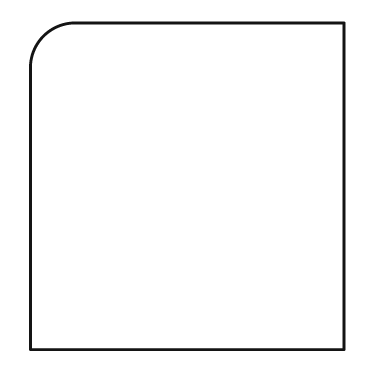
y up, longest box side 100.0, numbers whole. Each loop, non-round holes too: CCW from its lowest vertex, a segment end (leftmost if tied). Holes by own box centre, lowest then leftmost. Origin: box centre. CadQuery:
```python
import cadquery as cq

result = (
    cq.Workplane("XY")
    .moveTo(-48.0, -50.0)
    .lineTo(48.0, -50.0)
    .lineTo(48.0, 50.0)
    .lineTo(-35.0, 50.0)
    .threePointArc((-44.0, 46.0), (-48.0, 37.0))
    .close()
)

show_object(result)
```